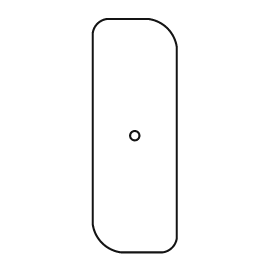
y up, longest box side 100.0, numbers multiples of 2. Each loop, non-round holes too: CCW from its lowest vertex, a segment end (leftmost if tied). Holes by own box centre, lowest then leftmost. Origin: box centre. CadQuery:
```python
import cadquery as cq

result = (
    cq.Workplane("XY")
    .moveTo(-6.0, -50.0)
    .lineTo(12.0, -50.0)
    .threePointArc((16.0, -48.0), (18.0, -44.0))
    .lineTo(18.0, 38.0)
    .threePointArc((14.0, 46.0), (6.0, 50.0))
    .lineTo(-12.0, 50.0)
    .threePointArc((-16.0, 48.0), (-18.0, 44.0))
    .lineTo(-18.0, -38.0)
    .threePointArc((-14.0, -46.0), (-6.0, -50.0))
    .close()
    .moveTo(0.0, 0.0)
    .circle(2.0)
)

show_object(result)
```